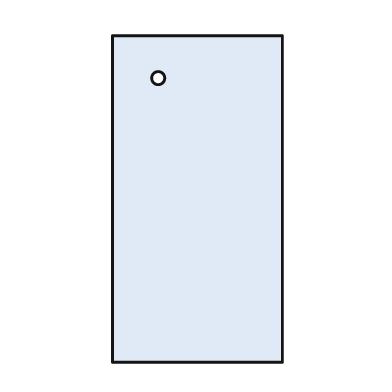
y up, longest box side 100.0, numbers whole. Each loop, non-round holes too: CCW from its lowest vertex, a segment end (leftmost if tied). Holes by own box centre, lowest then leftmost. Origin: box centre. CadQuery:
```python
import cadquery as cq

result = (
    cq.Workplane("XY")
    .moveTo(-26.0, -50.0)
    .lineTo(26.0, -50.0)
    .lineTo(26.0, 50.0)
    .lineTo(-26.0, 50.0)
    .close()
    .moveTo(-12.0, 37.0)
    .circle(2.0)
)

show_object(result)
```